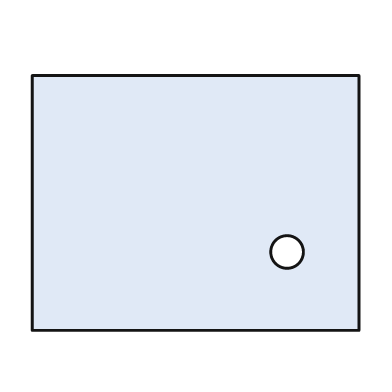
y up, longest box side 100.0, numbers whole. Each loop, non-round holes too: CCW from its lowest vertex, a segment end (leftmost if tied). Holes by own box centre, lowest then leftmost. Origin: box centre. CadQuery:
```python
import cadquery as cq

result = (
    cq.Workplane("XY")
    .moveTo(-50.0, -39.0)
    .lineTo(50.0, -39.0)
    .lineTo(50.0, 39.0)
    .lineTo(-50.0, 39.0)
    .close()
    .moveTo(28.0, -15.0)
    .circle(5.0)
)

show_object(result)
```